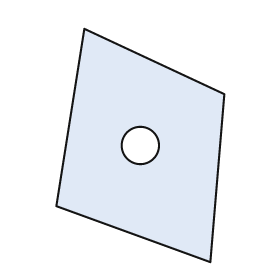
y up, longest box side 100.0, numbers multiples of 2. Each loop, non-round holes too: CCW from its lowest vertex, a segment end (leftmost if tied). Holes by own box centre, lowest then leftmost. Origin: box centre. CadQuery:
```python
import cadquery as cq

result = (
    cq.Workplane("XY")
    .moveTo(30.0, -50.0)
    .lineTo(36.0, 22.0)
    .lineTo(-24.0, 50.0)
    .lineTo(-36.0, -26.0)
    .close()
    .moveTo(0.0, 0.0)
    .circle(8.0)
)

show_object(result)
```